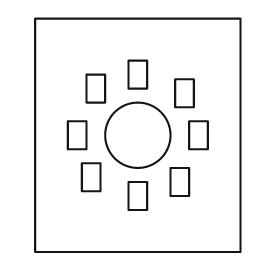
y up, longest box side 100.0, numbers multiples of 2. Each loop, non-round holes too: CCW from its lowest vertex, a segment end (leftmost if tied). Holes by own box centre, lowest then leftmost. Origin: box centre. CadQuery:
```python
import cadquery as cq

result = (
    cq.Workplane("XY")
    .moveTo(-44.0, -50.0)
    .lineTo(44.0, -50.0)
    .lineTo(44.0, 50.0)
    .lineTo(-44.0, 50.0)
    .close()
    .moveTo(-4.0, -32.0)
    .lineTo(4.0, -32.0)
    .lineTo(4.0, -20.0)
    .lineTo(-4.0, -20.0)
    .close()
    .moveTo(14.0, -26.0)
    .lineTo(22.0, -26.0)
    .lineTo(22.0, -14.0)
    .lineTo(14.0, -14.0)
    .close()
    .moveTo(-24.0, -24.0)
    .lineTo(-16.0, -24.0)
    .lineTo(-16.0, -12.0)
    .lineTo(-24.0, -12.0)
    .close()
    .moveTo(-30.0, -6.0)
    .lineTo(-22.0, -6.0)
    .lineTo(-22.0, 6.0)
    .lineTo(-30.0, 6.0)
    .close()
    .moveTo(0.0, 0.0)
    .circle(14.0)
    .moveTo(22.0, -6.0)
    .lineTo(30.0, -6.0)
    .lineTo(30.0, 6.0)
    .lineTo(22.0, 6.0)
    .close()
    .moveTo(16.0, 12.0)
    .lineTo(24.0, 12.0)
    .lineTo(24.0, 24.0)
    .lineTo(16.0, 24.0)
    .close()
    .moveTo(-22.0, 14.0)
    .lineTo(-14.0, 14.0)
    .lineTo(-14.0, 26.0)
    .lineTo(-22.0, 26.0)
    .close()
    .moveTo(-4.0, 20.0)
    .lineTo(4.0, 20.0)
    .lineTo(4.0, 32.0)
    .lineTo(-4.0, 32.0)
    .close()
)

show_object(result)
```